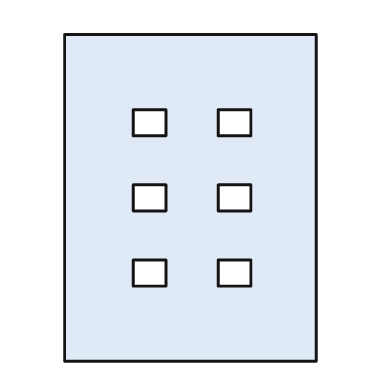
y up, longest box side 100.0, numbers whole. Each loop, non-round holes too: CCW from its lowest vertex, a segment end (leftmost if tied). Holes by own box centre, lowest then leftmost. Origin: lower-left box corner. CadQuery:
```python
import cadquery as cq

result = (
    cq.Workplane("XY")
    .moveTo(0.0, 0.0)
    .lineTo(77.0, 0.0)
    .lineTo(77.0, 100.0)
    .lineTo(0.0, 100.0)
    .close()
    .moveTo(21.0, 23.0)
    .lineTo(31.0, 23.0)
    .lineTo(31.0, 31.0)
    .lineTo(21.0, 31.0)
    .close()
    .moveTo(47.0, 23.0)
    .lineTo(57.0, 23.0)
    .lineTo(57.0, 31.0)
    .lineTo(47.0, 31.0)
    .close()
    .moveTo(21.0, 46.0)
    .lineTo(31.0, 46.0)
    .lineTo(31.0, 54.0)
    .lineTo(21.0, 54.0)
    .close()
    .moveTo(47.0, 46.0)
    .lineTo(57.0, 46.0)
    .lineTo(57.0, 54.0)
    .lineTo(47.0, 54.0)
    .close()
    .moveTo(21.0, 69.0)
    .lineTo(31.0, 69.0)
    .lineTo(31.0, 77.0)
    .lineTo(21.0, 77.0)
    .close()
    .moveTo(47.0, 69.0)
    .lineTo(57.0, 69.0)
    .lineTo(57.0, 77.0)
    .lineTo(47.0, 77.0)
    .close()
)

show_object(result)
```